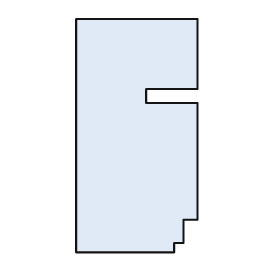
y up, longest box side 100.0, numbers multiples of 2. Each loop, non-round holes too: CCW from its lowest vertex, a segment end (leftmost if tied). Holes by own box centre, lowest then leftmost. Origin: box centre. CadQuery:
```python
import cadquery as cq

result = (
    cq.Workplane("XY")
    .moveTo(-26.0, -50.0)
    .lineTo(16.0, -50.0)
    .lineTo(16.0, -46.0)
    .lineTo(20.0, -46.0)
    .lineTo(20.0, -36.0)
    .lineTo(26.0, -36.0)
    .lineTo(26.0, 14.0)
    .lineTo(4.0, 14.0)
    .lineTo(4.0, 20.0)
    .lineTo(26.0, 20.0)
    .lineTo(26.0, 50.0)
    .lineTo(-26.0, 50.0)
    .close()
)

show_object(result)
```